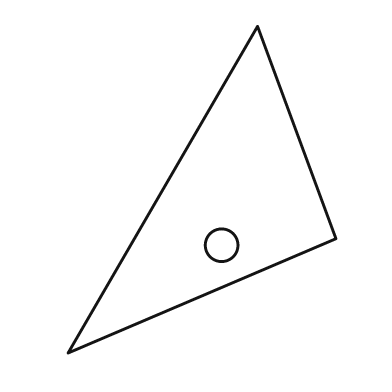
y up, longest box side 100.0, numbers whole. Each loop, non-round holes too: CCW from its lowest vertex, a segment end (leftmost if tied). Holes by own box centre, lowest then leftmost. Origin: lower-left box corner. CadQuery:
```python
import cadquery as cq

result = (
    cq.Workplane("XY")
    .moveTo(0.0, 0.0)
    .lineTo(82.0, 35.0)
    .lineTo(58.0, 100.0)
    .close()
    .moveTo(47.0, 33.0)
    .circle(5.0)
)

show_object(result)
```